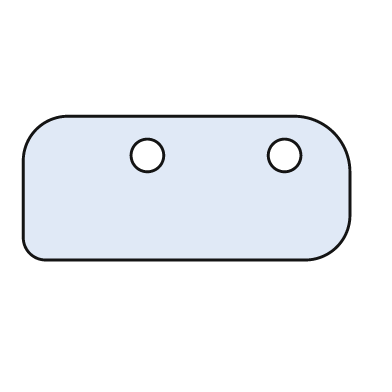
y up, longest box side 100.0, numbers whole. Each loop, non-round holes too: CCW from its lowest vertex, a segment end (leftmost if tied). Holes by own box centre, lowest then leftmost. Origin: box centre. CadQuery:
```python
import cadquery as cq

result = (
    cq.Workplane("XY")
    .moveTo(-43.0, -22.0)
    .lineTo(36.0, -22.0)
    .threePointArc((46.0, -18.0), (50.0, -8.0))
    .lineTo(50.0, 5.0)
    .threePointArc((45.0, 17.0), (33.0, 22.0))
    .lineTo(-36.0, 22.0)
    .threePointArc((-46.0, 18.0), (-50.0, 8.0))
    .lineTo(-50.0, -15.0)
    .threePointArc((-48.0, -20.0), (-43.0, -22.0))
    .close()
    .moveTo(-12.0, 10.0)
    .circle(5.0)
    .moveTo(30.0, 10.0)
    .circle(5.0)
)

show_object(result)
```